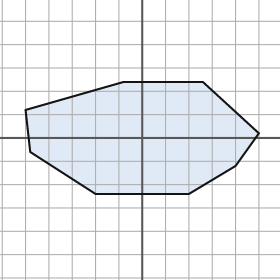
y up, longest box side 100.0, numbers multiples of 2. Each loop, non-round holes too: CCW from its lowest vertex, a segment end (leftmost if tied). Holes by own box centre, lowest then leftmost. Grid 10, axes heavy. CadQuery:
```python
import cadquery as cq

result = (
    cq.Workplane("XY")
    .moveTo(-20.0, -24.0)
    .lineTo(20.0, -24.0)
    .lineTo(40.0, -12.0)
    .lineTo(50.0, 2.0)
    .lineTo(26.0, 24.0)
    .lineTo(-8.0, 24.0)
    .lineTo(-50.0, 12.0)
    .lineTo(-48.0, -6.0)
    .close()
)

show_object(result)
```